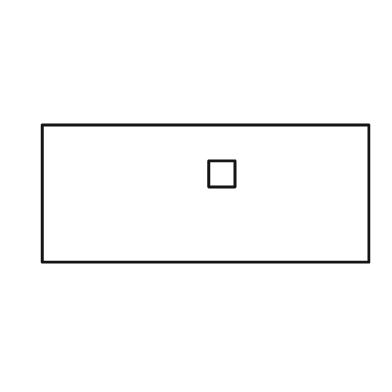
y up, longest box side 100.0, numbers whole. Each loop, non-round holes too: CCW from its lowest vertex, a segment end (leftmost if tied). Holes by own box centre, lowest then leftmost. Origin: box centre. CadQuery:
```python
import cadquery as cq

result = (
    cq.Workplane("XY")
    .moveTo(-50.0, -21.0)
    .lineTo(50.0, -21.0)
    .lineTo(50.0, 21.0)
    .lineTo(-50.0, 21.0)
    .close()
    .moveTo(1.0, 2.0)
    .lineTo(9.0, 2.0)
    .lineTo(9.0, 10.0)
    .lineTo(1.0, 10.0)
    .close()
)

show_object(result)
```